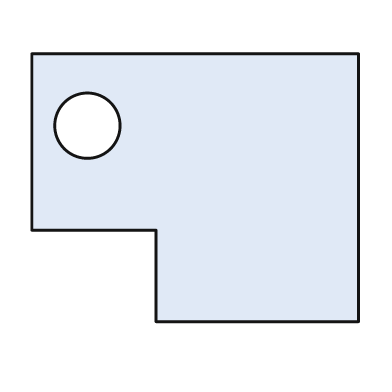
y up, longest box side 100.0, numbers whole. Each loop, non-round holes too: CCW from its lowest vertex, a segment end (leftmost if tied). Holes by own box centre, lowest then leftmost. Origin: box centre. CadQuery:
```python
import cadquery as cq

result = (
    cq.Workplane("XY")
    .moveTo(-12.0, -41.0)
    .lineTo(50.0, -41.0)
    .lineTo(50.0, 41.0)
    .lineTo(-50.0, 41.0)
    .lineTo(-50.0, -13.0)
    .lineTo(-12.0, -13.0)
    .close()
    .moveTo(-33.0, 19.0)
    .circle(10.0)
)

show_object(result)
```